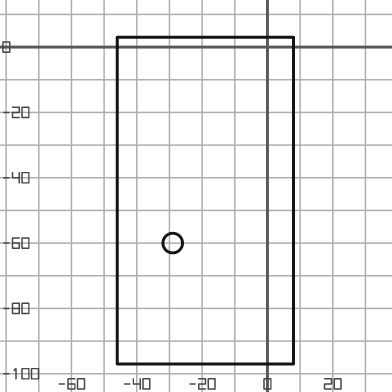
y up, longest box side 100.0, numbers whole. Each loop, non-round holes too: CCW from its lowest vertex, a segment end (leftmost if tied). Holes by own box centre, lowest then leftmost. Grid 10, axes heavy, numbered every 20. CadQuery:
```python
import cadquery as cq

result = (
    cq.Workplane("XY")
    .moveTo(-46.0, -97.0)
    .lineTo(8.0, -97.0)
    .lineTo(8.0, 3.0)
    .lineTo(-46.0, 3.0)
    .close()
    .moveTo(-29.0, -60.0)
    .circle(3.0)
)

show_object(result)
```